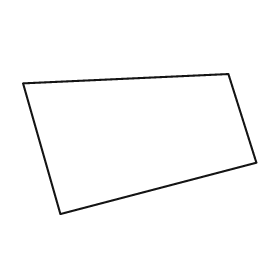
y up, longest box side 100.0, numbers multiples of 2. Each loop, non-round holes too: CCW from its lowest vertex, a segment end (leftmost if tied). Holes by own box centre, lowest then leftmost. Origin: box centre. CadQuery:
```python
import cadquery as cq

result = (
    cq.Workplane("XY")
    .moveTo(-34.0, -30.0)
    .lineTo(50.0, -8.0)
    .lineTo(38.0, 30.0)
    .lineTo(-50.0, 26.0)
    .close()
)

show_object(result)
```